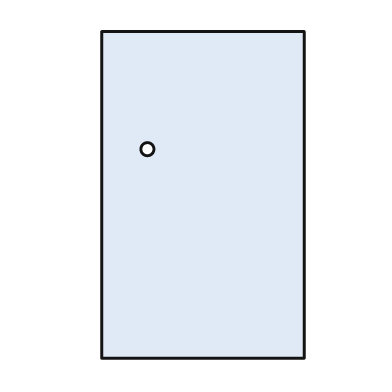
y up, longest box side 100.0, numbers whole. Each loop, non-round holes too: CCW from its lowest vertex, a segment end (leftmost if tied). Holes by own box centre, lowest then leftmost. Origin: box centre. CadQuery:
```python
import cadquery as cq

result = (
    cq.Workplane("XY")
    .moveTo(-31.0, -50.0)
    .lineTo(31.0, -50.0)
    .lineTo(31.0, 50.0)
    .lineTo(-31.0, 50.0)
    .close()
    .moveTo(-17.0, 14.0)
    .circle(2.0)
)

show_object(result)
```